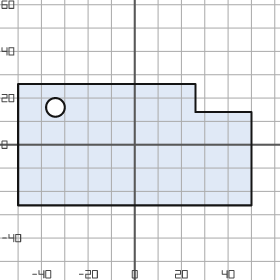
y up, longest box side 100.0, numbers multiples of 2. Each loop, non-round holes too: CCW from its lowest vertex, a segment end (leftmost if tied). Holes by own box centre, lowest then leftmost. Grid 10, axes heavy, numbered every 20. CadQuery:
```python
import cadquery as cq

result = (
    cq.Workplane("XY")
    .moveTo(-50.0, -26.0)
    .lineTo(50.0, -26.0)
    .lineTo(50.0, 14.0)
    .lineTo(26.0, 14.0)
    .lineTo(26.0, 26.0)
    .lineTo(-50.0, 26.0)
    .close()
    .moveTo(-34.0, 16.0)
    .circle(4.0)
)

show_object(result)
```